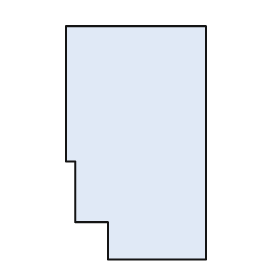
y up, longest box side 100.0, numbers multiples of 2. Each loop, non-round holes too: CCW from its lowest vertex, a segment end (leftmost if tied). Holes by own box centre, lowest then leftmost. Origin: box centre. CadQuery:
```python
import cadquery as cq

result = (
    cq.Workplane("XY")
    .moveTo(-12.0, -50.0)
    .lineTo(30.0, -50.0)
    .lineTo(30.0, 50.0)
    .lineTo(-30.0, 50.0)
    .lineTo(-30.0, -8.0)
    .lineTo(-26.0, -8.0)
    .lineTo(-26.0, -34.0)
    .lineTo(-12.0, -34.0)
    .close()
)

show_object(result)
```